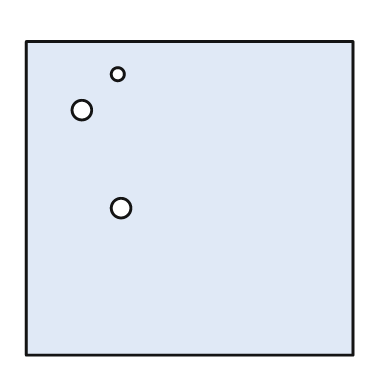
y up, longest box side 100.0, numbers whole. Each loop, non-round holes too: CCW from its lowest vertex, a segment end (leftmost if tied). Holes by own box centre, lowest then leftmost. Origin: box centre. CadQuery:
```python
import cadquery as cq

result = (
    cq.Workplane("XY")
    .moveTo(-50.0, -48.0)
    .lineTo(50.0, -48.0)
    .lineTo(50.0, 48.0)
    .lineTo(-50.0, 48.0)
    .close()
    .moveTo(-21.0, -3.0)
    .circle(3.0)
    .moveTo(-33.0, 27.0)
    .circle(3.0)
    .moveTo(-22.0, 38.0)
    .circle(2.0)
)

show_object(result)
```